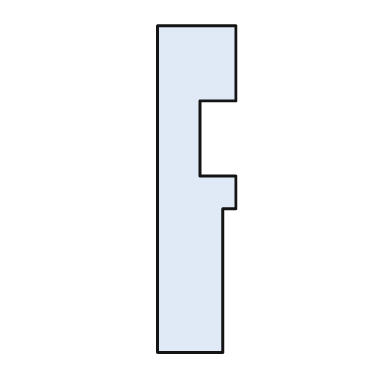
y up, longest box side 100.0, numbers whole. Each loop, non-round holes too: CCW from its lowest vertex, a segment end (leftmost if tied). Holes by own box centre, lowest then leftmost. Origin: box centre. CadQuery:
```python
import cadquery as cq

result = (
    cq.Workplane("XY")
    .moveTo(-12.0, -50.0)
    .lineTo(8.0, -50.0)
    .lineTo(8.0, -6.0)
    .lineTo(12.0, -6.0)
    .lineTo(12.0, 4.0)
    .lineTo(1.0, 4.0)
    .lineTo(1.0, 27.0)
    .lineTo(12.0, 27.0)
    .lineTo(12.0, 50.0)
    .lineTo(-12.0, 50.0)
    .close()
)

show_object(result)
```